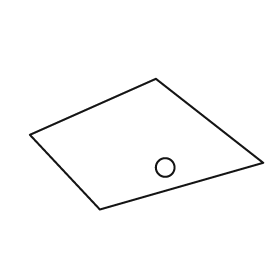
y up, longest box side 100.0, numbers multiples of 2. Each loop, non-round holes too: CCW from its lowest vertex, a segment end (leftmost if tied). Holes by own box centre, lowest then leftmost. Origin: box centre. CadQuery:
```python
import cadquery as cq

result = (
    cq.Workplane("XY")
    .moveTo(-20.0, -28.0)
    .lineTo(50.0, -8.0)
    .lineTo(4.0, 28.0)
    .lineTo(-50.0, 4.0)
    .close()
    .moveTo(8.0, -10.0)
    .circle(4.0)
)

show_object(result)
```